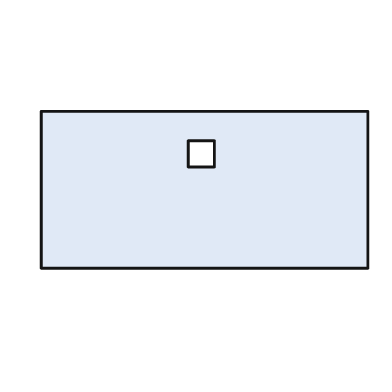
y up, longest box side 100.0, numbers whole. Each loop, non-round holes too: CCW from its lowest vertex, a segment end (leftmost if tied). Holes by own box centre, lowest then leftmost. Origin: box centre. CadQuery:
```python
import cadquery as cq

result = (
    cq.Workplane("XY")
    .moveTo(-50.0, -24.0)
    .lineTo(50.0, -24.0)
    .lineTo(50.0, 24.0)
    .lineTo(-50.0, 24.0)
    .close()
    .moveTo(-5.0, 7.0)
    .lineTo(3.0, 7.0)
    .lineTo(3.0, 15.0)
    .lineTo(-5.0, 15.0)
    .close()
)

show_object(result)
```